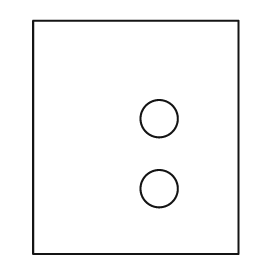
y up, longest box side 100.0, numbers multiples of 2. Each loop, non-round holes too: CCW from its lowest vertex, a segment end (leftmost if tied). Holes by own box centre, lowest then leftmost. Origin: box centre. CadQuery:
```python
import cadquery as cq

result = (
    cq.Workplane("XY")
    .moveTo(-44.0, -50.0)
    .lineTo(44.0, -50.0)
    .lineTo(44.0, 50.0)
    .lineTo(-44.0, 50.0)
    .close()
    .moveTo(10.0, -22.0)
    .circle(8.0)
    .moveTo(10.0, 8.0)
    .circle(8.0)
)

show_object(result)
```